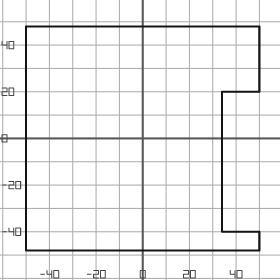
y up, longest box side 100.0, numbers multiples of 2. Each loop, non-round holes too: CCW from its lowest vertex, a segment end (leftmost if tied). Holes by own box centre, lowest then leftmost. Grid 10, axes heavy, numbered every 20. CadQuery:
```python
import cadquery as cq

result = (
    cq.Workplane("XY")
    .moveTo(-50.0, -48.0)
    .lineTo(50.0, -48.0)
    .lineTo(50.0, -40.0)
    .lineTo(34.0, -40.0)
    .lineTo(34.0, 20.0)
    .lineTo(50.0, 20.0)
    .lineTo(50.0, 48.0)
    .lineTo(-50.0, 48.0)
    .close()
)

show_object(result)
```